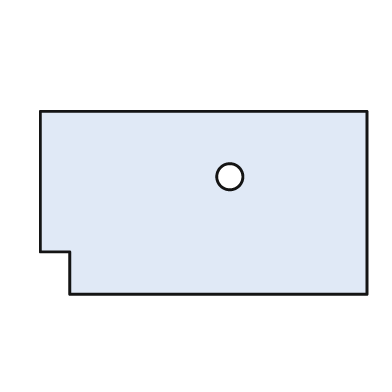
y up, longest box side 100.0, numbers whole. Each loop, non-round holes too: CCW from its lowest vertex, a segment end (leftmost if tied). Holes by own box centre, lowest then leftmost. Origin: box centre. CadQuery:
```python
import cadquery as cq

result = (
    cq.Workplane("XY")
    .moveTo(-41.0, -28.0)
    .lineTo(50.0, -28.0)
    .lineTo(50.0, 28.0)
    .lineTo(-50.0, 28.0)
    .lineTo(-50.0, -15.0)
    .lineTo(-41.0, -15.0)
    .close()
    .moveTo(8.0, 8.0)
    .circle(4.0)
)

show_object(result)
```